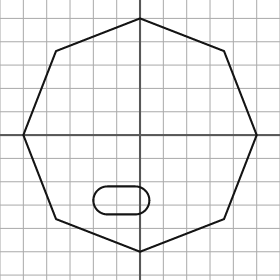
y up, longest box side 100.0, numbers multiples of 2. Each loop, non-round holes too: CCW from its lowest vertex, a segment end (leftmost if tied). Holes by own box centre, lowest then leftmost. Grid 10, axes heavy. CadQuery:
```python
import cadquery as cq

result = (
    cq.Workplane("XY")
    .moveTo(0.0, -50.0)
    .lineTo(36.0, -36.0)
    .lineTo(50.0, 0.0)
    .lineTo(36.0, 36.0)
    .lineTo(0.0, 50.0)
    .lineTo(-36.0, 36.0)
    .lineTo(-50.0, 0.0)
    .lineTo(-36.0, -36.0)
    .close()
    .moveTo(-14.0, -34.0)
    .lineTo(-2.0, -34.0)
    .threePointArc((4.0, -28.0), (-2.0, -22.0))
    .lineTo(-14.0, -22.0)
    .threePointArc((-20.0, -28.0), (-14.0, -34.0))
    .close()
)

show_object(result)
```